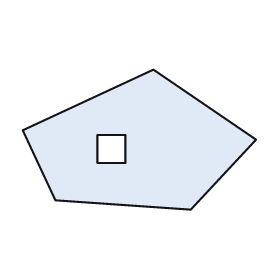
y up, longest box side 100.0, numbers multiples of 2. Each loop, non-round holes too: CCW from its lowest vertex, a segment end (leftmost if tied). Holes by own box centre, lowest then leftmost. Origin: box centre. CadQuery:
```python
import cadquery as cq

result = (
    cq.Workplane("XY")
    .moveTo(22.0, -30.0)
    .lineTo(50.0, 0.0)
    .lineTo(6.0, 30.0)
    .lineTo(-50.0, 4.0)
    .lineTo(-36.0, -26.0)
    .close()
    .moveTo(-18.0, -10.0)
    .lineTo(-6.0, -10.0)
    .lineTo(-6.0, 2.0)
    .lineTo(-18.0, 2.0)
    .close()
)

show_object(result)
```